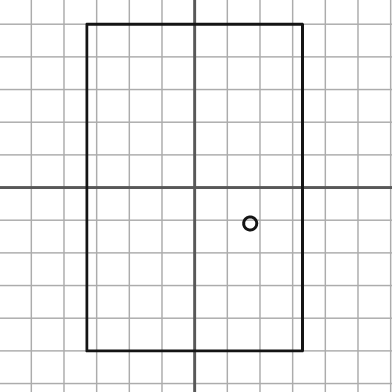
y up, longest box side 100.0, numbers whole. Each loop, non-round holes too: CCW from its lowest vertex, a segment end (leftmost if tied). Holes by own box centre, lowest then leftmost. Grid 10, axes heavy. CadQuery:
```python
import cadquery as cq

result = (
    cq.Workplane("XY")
    .moveTo(-33.0, -50.0)
    .lineTo(33.0, -50.0)
    .lineTo(33.0, 50.0)
    .lineTo(-33.0, 50.0)
    .close()
    .moveTo(17.0, -11.0)
    .circle(2.0)
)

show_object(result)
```